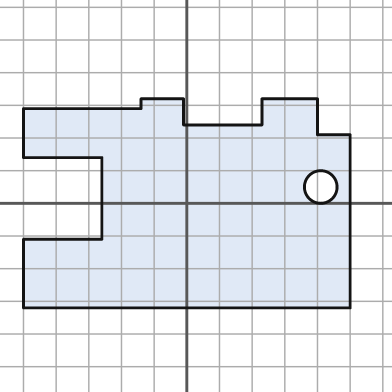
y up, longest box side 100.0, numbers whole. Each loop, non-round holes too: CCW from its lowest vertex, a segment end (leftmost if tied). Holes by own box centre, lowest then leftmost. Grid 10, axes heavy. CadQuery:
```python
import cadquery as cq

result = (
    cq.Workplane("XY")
    .moveTo(-50.0, -32.0)
    .lineTo(50.0, -32.0)
    .lineTo(50.0, 21.0)
    .lineTo(40.0, 21.0)
    .lineTo(40.0, 32.0)
    .lineTo(23.0, 32.0)
    .lineTo(23.0, 24.0)
    .lineTo(-1.0, 24.0)
    .lineTo(-1.0, 32.0)
    .lineTo(-14.0, 32.0)
    .lineTo(-14.0, 29.0)
    .lineTo(-50.0, 29.0)
    .lineTo(-50.0, 14.0)
    .lineTo(-26.0, 14.0)
    .lineTo(-26.0, -11.0)
    .lineTo(-50.0, -11.0)
    .close()
    .moveTo(41.0, 5.0)
    .circle(5.0)
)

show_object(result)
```